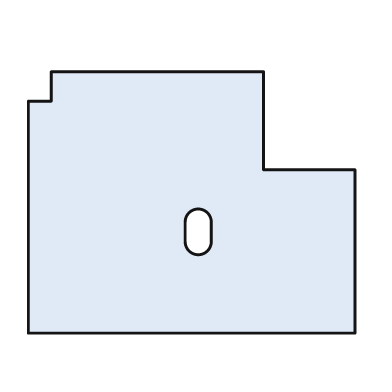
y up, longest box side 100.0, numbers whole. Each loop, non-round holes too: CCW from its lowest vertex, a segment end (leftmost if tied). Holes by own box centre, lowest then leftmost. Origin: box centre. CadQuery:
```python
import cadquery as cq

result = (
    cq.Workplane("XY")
    .moveTo(-50.0, -40.0)
    .lineTo(50.0, -40.0)
    .lineTo(50.0, 10.0)
    .lineTo(22.0, 10.0)
    .lineTo(22.0, 40.0)
    .lineTo(-43.0, 40.0)
    .lineTo(-43.0, 31.0)
    .lineTo(-50.0, 31.0)
    .close()
    .moveTo(-2.0, -12.0)
    .threePointArc((2.0, -16.0), (6.0, -12.0))
    .lineTo(6.0, -6.0)
    .threePointArc((2.0, -2.0), (-2.0, -6.0))
    .close()
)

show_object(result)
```